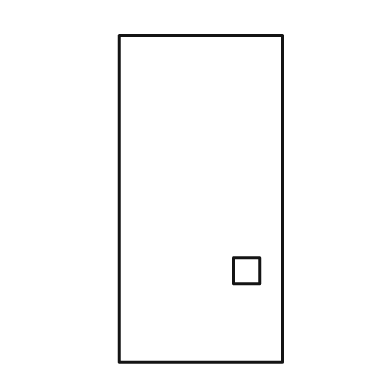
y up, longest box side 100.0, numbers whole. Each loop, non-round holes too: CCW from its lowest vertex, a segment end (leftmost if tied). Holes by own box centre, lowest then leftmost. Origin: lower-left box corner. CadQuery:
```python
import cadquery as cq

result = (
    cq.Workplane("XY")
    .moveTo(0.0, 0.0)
    .lineTo(50.0, 0.0)
    .lineTo(50.0, 100.0)
    .lineTo(0.0, 100.0)
    .close()
    .moveTo(35.0, 24.0)
    .lineTo(43.0, 24.0)
    .lineTo(43.0, 32.0)
    .lineTo(35.0, 32.0)
    .close()
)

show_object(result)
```